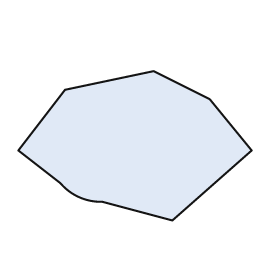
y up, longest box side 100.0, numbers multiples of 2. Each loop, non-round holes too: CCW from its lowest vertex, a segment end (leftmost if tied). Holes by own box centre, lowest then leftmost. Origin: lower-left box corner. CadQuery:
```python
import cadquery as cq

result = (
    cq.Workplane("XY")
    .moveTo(66.0, 0.0)
    .lineTo(100.0, 30.0)
    .lineTo(82.0, 52.0)
    .lineTo(58.0, 64.0)
    .lineTo(20.0, 56.0)
    .lineTo(0.0, 30.0)
    .lineTo(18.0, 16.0)
    .threePointArc((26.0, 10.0), (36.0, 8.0))
    .close()
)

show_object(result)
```